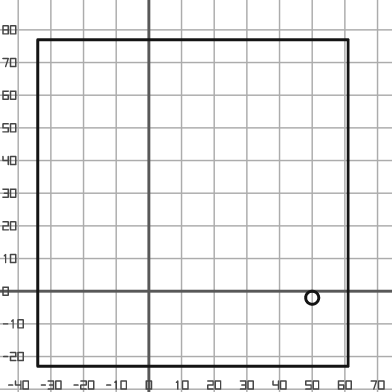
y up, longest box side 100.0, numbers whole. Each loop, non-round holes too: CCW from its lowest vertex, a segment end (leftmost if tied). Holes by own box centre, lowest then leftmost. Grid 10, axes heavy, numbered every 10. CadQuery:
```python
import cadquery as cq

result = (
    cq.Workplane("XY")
    .moveTo(-34.0, -23.0)
    .lineTo(61.0, -23.0)
    .lineTo(61.0, 77.0)
    .lineTo(-34.0, 77.0)
    .close()
    .moveTo(50.0, -2.0)
    .circle(2.0)
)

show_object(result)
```